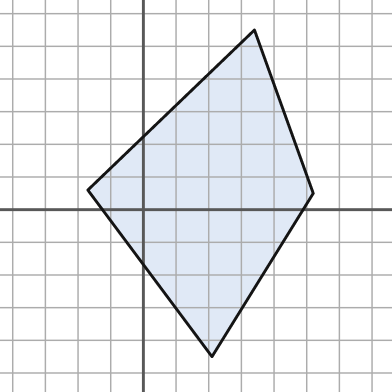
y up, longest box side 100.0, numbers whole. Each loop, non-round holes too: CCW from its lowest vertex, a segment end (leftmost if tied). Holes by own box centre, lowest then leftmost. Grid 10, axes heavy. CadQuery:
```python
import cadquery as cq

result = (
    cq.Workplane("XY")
    .moveTo(21.0, -45.0)
    .lineTo(52.0, 5.0)
    .lineTo(34.0, 55.0)
    .lineTo(-17.0, 6.0)
    .close()
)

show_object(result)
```